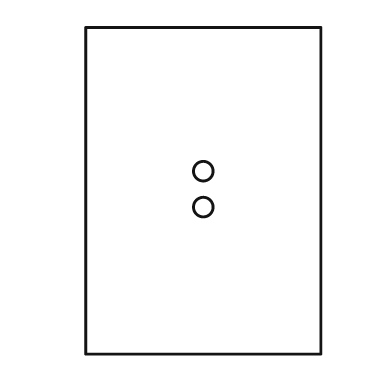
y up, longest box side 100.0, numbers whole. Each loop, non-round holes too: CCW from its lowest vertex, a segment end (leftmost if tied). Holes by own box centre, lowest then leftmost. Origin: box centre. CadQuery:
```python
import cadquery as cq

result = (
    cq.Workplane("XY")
    .moveTo(-36.0, -50.0)
    .lineTo(36.0, -50.0)
    .lineTo(36.0, 50.0)
    .lineTo(-36.0, 50.0)
    .close()
    .moveTo(0.0, -5.0)
    .circle(3.0)
    .moveTo(0.0, 6.0)
    .circle(3.0)
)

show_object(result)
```